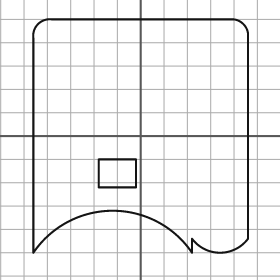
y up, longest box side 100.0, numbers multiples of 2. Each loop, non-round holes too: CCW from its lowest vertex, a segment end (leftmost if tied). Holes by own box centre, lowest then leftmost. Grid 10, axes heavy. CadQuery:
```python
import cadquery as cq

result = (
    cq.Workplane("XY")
    .moveTo(-46.0, -50.0)
    .threePointArc((-12.0, -32.0), (22.0, -50.0))
    .lineTo(22.0, -44.0)
    .threePointArc((34.0, -50.0), (46.0, -44.0))
    .lineTo(46.0, 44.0)
    .threePointArc((44.0, 48.0), (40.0, 50.0))
    .lineTo(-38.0, 50.0)
    .threePointArc((-44.0, 48.0), (-46.0, 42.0))
    .close()
    .moveTo(-18.0, -22.0)
    .lineTo(-2.0, -22.0)
    .lineTo(-2.0, -10.0)
    .lineTo(-18.0, -10.0)
    .close()
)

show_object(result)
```